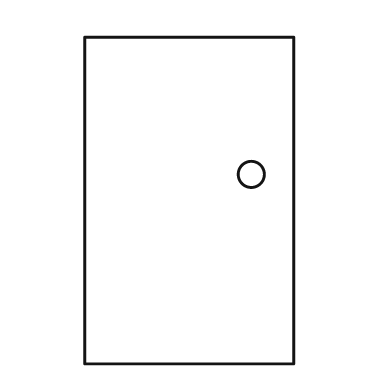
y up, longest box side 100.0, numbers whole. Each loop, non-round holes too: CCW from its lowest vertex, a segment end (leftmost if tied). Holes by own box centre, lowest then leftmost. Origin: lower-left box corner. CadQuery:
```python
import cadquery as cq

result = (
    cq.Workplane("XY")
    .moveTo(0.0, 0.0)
    .lineTo(64.0, 0.0)
    .lineTo(64.0, 100.0)
    .lineTo(0.0, 100.0)
    .close()
    .moveTo(51.0, 58.0)
    .circle(4.0)
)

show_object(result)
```